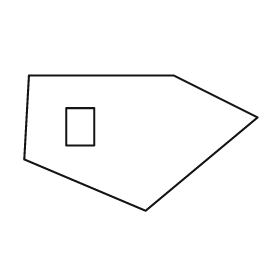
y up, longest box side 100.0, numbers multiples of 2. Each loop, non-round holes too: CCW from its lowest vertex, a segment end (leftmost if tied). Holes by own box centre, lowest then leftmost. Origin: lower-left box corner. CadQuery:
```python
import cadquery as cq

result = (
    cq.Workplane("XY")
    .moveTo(52.0, 0.0)
    .lineTo(100.0, 40.0)
    .lineTo(64.0, 58.0)
    .lineTo(2.0, 58.0)
    .lineTo(0.0, 22.0)
    .close()
    .moveTo(18.0, 28.0)
    .lineTo(30.0, 28.0)
    .lineTo(30.0, 44.0)
    .lineTo(18.0, 44.0)
    .close()
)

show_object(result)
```